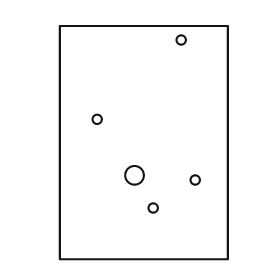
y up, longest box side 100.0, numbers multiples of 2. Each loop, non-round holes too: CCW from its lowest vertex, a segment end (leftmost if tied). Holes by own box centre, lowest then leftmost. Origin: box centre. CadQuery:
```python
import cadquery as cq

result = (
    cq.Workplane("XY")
    .moveTo(-36.0, -50.0)
    .lineTo(36.0, -50.0)
    .lineTo(36.0, 50.0)
    .lineTo(-36.0, 50.0)
    .close()
    .moveTo(4.0, -28.0)
    .circle(2.0)
    .moveTo(22.0, -16.0)
    .circle(2.0)
    .moveTo(-4.0, -14.0)
    .circle(4.0)
    .moveTo(-20.0, 10.0)
    .circle(2.0)
    .moveTo(16.0, 44.0)
    .circle(2.0)
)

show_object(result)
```